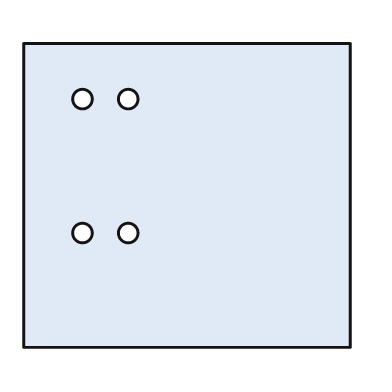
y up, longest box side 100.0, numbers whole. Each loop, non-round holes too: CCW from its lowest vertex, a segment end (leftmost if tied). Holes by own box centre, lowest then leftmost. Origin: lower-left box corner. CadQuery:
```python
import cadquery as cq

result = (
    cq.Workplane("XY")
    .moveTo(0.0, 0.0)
    .lineTo(100.0, 0.0)
    .lineTo(100.0, 93.0)
    .lineTo(0.0, 93.0)
    .close()
    .moveTo(18.0, 35.0)
    .circle(3.0)
    .moveTo(32.0, 35.0)
    .circle(3.0)
    .moveTo(18.0, 76.0)
    .circle(3.0)
    .moveTo(32.0, 76.0)
    .circle(3.0)
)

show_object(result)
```